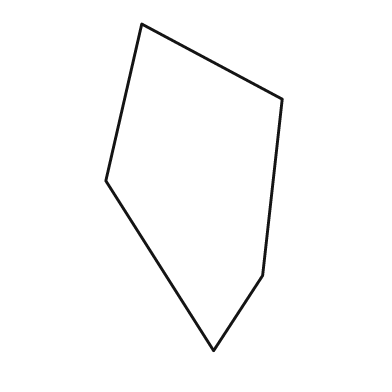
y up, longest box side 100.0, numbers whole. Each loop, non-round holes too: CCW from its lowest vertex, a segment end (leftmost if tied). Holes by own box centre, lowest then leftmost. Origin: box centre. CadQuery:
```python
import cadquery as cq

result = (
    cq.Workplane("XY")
    .moveTo(6.0, -50.0)
    .lineTo(21.0, -27.0)
    .lineTo(27.0, 27.0)
    .lineTo(-16.0, 50.0)
    .lineTo(-27.0, 2.0)
    .close()
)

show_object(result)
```